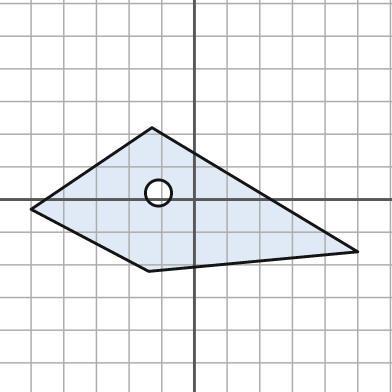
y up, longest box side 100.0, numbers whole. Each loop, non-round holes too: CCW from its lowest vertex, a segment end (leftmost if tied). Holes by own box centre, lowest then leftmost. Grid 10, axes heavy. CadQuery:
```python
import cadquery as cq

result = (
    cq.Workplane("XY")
    .moveTo(-14.0, -22.0)
    .lineTo(50.0, -16.0)
    .lineTo(-13.0, 22.0)
    .lineTo(-50.0, -3.0)
    .close()
    .moveTo(-11.0, 2.0)
    .circle(4.0)
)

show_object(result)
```